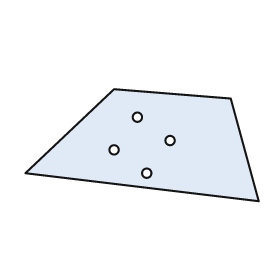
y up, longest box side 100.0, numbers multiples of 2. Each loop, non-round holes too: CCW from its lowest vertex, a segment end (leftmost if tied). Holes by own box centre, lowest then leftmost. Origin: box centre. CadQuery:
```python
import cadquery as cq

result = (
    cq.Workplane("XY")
    .moveTo(50.0, -24.0)
    .lineTo(38.0, 20.0)
    .lineTo(-12.0, 24.0)
    .lineTo(-50.0, -12.0)
    .close()
    .moveTo(2.0, -12.0)
    .circle(2.0)
    .moveTo(-12.0, -2.0)
    .circle(2.0)
    .moveTo(12.0, 2.0)
    .circle(2.0)
    .moveTo(-2.0, 12.0)
    .circle(2.0)
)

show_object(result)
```